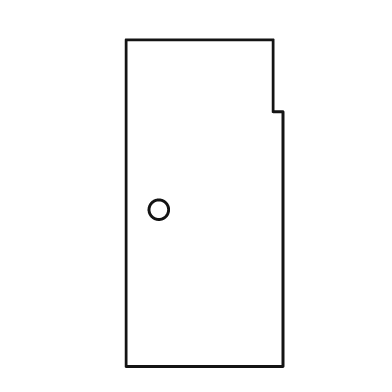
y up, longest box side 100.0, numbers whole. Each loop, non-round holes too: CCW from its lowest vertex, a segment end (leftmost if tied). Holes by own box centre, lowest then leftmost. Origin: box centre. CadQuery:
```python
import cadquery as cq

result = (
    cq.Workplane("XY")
    .moveTo(-24.0, -50.0)
    .lineTo(24.0, -50.0)
    .lineTo(24.0, 28.0)
    .lineTo(21.0, 28.0)
    .lineTo(21.0, 50.0)
    .lineTo(-24.0, 50.0)
    .close()
    .moveTo(-14.0, -2.0)
    .circle(3.0)
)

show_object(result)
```